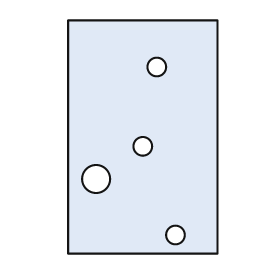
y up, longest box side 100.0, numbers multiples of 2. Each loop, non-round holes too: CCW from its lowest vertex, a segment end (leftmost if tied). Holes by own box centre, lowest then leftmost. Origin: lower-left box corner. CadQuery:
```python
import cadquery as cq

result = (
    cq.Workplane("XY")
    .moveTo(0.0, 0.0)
    .lineTo(64.0, 0.0)
    .lineTo(64.0, 100.0)
    .lineTo(0.0, 100.0)
    .close()
    .moveTo(46.0, 8.0)
    .circle(4.0)
    .moveTo(12.0, 32.0)
    .circle(6.0)
    .moveTo(32.0, 46.0)
    .circle(4.0)
    .moveTo(38.0, 80.0)
    .circle(4.0)
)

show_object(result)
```